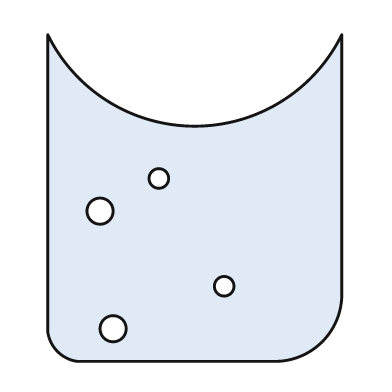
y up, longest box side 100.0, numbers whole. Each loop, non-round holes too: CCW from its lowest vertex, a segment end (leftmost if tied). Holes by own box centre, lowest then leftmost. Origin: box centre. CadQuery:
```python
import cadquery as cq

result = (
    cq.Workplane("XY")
    .moveTo(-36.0, -50.0)
    .lineTo(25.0, -50.0)
    .threePointArc((39.0, -44.0), (45.0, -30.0))
    .lineTo(45.0, 50.0)
    .threePointArc((0.0, 22.0), (-45.0, 50.0))
    .lineTo(-45.0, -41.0)
    .threePointArc((-42.0, -47.0), (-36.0, -50.0))
    .close()
    .moveTo(-25.0, -40.0)
    .circle(4.0)
    .moveTo(9.0, -27.0)
    .circle(3.0)
    .moveTo(-29.0, -4.0)
    .circle(4.0)
    .moveTo(-11.0, 6.0)
    .circle(3.0)
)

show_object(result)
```